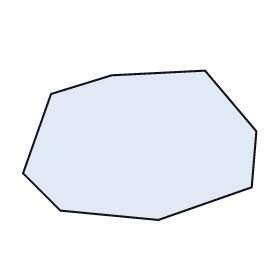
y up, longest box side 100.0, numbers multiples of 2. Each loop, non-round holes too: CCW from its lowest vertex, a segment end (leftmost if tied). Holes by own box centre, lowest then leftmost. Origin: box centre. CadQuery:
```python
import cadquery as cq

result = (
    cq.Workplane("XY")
    .moveTo(8.0, -32.0)
    .lineTo(48.0, -18.0)
    .lineTo(50.0, 6.0)
    .lineTo(28.0, 32.0)
    .lineTo(-12.0, 30.0)
    .lineTo(-38.0, 22.0)
    .lineTo(-50.0, -12.0)
    .lineTo(-34.0, -28.0)
    .close()
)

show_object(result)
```